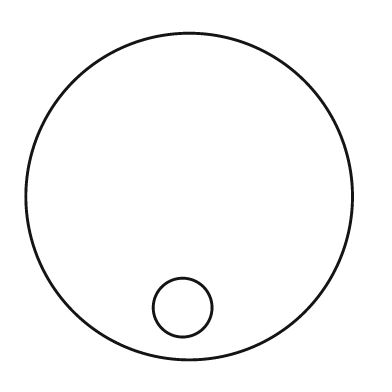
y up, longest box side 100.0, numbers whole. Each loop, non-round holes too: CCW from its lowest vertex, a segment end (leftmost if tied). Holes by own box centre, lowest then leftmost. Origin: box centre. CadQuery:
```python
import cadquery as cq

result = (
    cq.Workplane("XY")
    .moveTo(0.0, 0.0)
    .circle(50.0)
    .moveTo(-2.0, -34.0)
    .circle(9.0)
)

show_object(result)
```